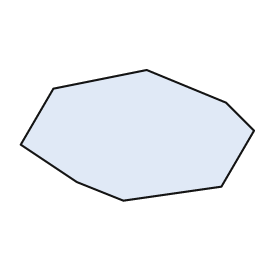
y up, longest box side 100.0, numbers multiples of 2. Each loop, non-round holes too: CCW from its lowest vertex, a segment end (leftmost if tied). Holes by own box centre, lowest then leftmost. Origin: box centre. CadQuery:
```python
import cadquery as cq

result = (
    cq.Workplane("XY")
    .moveTo(-6.0, -28.0)
    .lineTo(36.0, -22.0)
    .lineTo(50.0, 2.0)
    .lineTo(38.0, 14.0)
    .lineTo(4.0, 28.0)
    .lineTo(-36.0, 20.0)
    .lineTo(-50.0, -4.0)
    .lineTo(-26.0, -20.0)
    .close()
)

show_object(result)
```